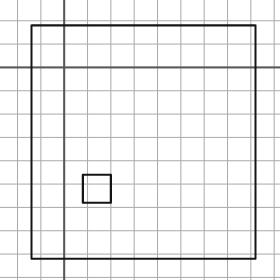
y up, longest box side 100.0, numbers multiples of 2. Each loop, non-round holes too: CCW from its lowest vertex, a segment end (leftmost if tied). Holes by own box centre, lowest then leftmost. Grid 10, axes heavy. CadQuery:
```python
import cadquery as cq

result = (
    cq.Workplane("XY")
    .moveTo(-14.0, -82.0)
    .lineTo(82.0, -82.0)
    .lineTo(82.0, 18.0)
    .lineTo(-14.0, 18.0)
    .close()
    .moveTo(8.0, -58.0)
    .lineTo(20.0, -58.0)
    .lineTo(20.0, -46.0)
    .lineTo(8.0, -46.0)
    .close()
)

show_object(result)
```